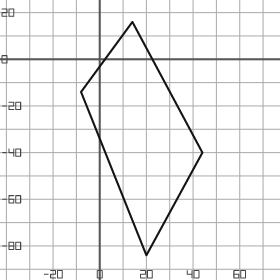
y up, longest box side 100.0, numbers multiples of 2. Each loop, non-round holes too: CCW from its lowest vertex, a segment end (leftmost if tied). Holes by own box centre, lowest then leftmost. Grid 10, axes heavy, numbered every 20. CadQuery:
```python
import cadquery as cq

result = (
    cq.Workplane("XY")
    .moveTo(20.0, -84.0)
    .lineTo(44.0, -40.0)
    .lineTo(14.0, 16.0)
    .lineTo(-8.0, -14.0)
    .close()
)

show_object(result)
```